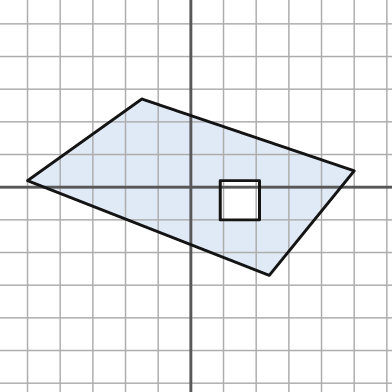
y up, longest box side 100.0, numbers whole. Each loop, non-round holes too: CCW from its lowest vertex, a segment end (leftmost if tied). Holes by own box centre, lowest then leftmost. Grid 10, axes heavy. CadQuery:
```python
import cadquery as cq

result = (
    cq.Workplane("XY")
    .moveTo(24.0, -27.0)
    .lineTo(50.0, 5.0)
    .lineTo(-15.0, 27.0)
    .lineTo(-50.0, 2.0)
    .close()
    .moveTo(9.0, -10.0)
    .lineTo(21.0, -10.0)
    .lineTo(21.0, 2.0)
    .lineTo(9.0, 2.0)
    .close()
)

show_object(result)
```